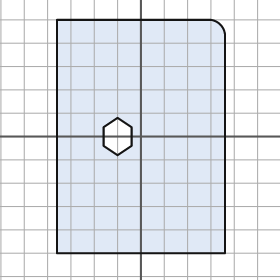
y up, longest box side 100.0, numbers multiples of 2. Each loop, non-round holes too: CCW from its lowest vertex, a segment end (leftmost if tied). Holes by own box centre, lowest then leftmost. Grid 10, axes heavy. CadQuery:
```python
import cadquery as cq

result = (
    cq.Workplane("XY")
    .moveTo(-36.0, -50.0)
    .lineTo(36.0, -50.0)
    .lineTo(36.0, 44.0)
    .threePointArc((34.0, 48.0), (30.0, 50.0))
    .lineTo(-36.0, 50.0)
    .close()
    .moveTo(-10.0, -8.0)
    .lineTo(-4.0, -4.0)
    .lineTo(-4.0, 4.0)
    .lineTo(-10.0, 8.0)
    .lineTo(-16.0, 4.0)
    .lineTo(-16.0, -4.0)
    .close()
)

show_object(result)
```